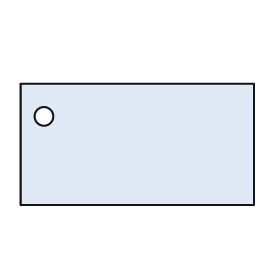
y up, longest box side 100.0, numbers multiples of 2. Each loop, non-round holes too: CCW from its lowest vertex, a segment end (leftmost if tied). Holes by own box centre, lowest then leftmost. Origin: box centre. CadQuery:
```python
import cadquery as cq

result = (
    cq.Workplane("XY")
    .moveTo(-50.0, -26.0)
    .lineTo(50.0, -26.0)
    .lineTo(50.0, 26.0)
    .lineTo(-50.0, 26.0)
    .close()
    .moveTo(-40.0, 12.0)
    .circle(4.0)
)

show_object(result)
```